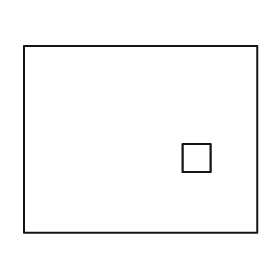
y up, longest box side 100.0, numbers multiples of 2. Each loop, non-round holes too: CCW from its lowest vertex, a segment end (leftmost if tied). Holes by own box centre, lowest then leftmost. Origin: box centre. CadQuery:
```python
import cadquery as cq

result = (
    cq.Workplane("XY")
    .moveTo(-50.0, -40.0)
    .lineTo(50.0, -40.0)
    .lineTo(50.0, 40.0)
    .lineTo(-50.0, 40.0)
    .close()
    .moveTo(18.0, -14.0)
    .lineTo(30.0, -14.0)
    .lineTo(30.0, -2.0)
    .lineTo(18.0, -2.0)
    .close()
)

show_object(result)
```